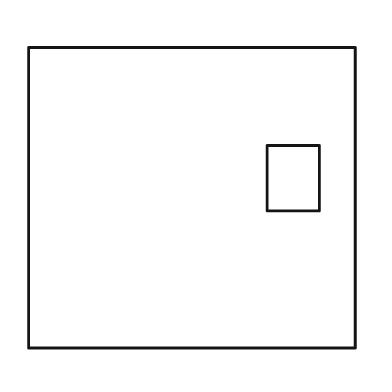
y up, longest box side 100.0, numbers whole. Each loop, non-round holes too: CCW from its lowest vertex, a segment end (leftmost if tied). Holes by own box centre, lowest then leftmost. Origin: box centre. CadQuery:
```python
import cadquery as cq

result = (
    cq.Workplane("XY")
    .moveTo(-50.0, -46.0)
    .lineTo(50.0, -46.0)
    .lineTo(50.0, 46.0)
    .lineTo(-50.0, 46.0)
    .close()
    .moveTo(23.0, -4.0)
    .lineTo(39.0, -4.0)
    .lineTo(39.0, 16.0)
    .lineTo(23.0, 16.0)
    .close()
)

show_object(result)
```